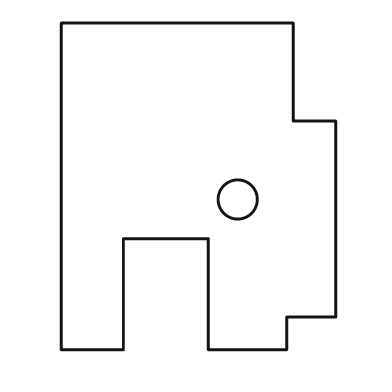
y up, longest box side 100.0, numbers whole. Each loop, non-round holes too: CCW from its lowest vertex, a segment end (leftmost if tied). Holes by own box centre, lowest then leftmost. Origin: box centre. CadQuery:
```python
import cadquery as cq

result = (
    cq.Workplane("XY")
    .moveTo(-42.0, -50.0)
    .lineTo(-23.0, -50.0)
    .lineTo(-23.0, -16.0)
    .lineTo(3.0, -16.0)
    .lineTo(3.0, -50.0)
    .lineTo(27.0, -50.0)
    .lineTo(27.0, -40.0)
    .lineTo(42.0, -40.0)
    .lineTo(42.0, 20.0)
    .lineTo(29.0, 20.0)
    .lineTo(29.0, 50.0)
    .lineTo(-42.0, 50.0)
    .close()
    .moveTo(12.0, -4.0)
    .circle(6.0)
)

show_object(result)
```